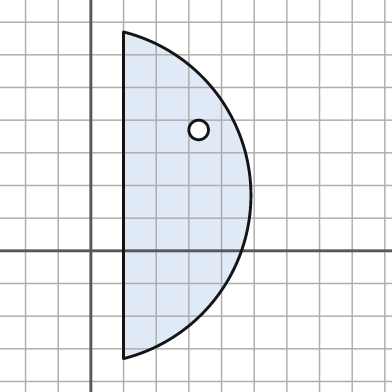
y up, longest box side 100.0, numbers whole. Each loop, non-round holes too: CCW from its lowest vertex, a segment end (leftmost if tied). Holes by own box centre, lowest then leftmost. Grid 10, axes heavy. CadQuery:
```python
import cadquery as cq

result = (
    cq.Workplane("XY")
    .moveTo(10.0, -33.0)
    .threePointArc((49.0, 17.0), (10.0, 67.0))
    .close()
    .moveTo(33.0, 37.0)
    .circle(3.0)
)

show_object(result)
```